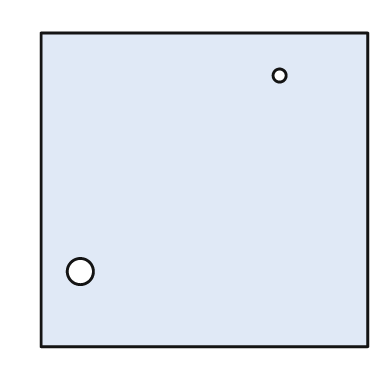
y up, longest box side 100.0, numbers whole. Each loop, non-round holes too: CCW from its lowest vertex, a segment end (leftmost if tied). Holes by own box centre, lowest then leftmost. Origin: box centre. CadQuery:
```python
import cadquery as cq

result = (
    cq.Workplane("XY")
    .moveTo(-50.0, -48.0)
    .lineTo(50.0, -48.0)
    .lineTo(50.0, 48.0)
    .lineTo(-50.0, 48.0)
    .close()
    .moveTo(-38.0, -25.0)
    .circle(4.0)
    .moveTo(23.0, 35.0)
    .circle(2.0)
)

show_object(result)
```